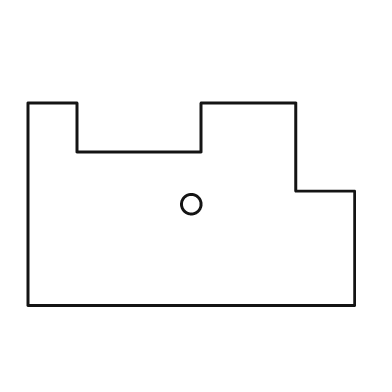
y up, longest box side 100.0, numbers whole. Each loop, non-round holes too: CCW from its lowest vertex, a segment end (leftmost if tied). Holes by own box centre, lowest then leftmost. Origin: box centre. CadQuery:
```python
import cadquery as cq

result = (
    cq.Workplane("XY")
    .moveTo(-50.0, -31.0)
    .lineTo(50.0, -31.0)
    .lineTo(50.0, 4.0)
    .lineTo(32.0, 4.0)
    .lineTo(32.0, 31.0)
    .lineTo(3.0, 31.0)
    .lineTo(3.0, 16.0)
    .lineTo(-35.0, 16.0)
    .lineTo(-35.0, 31.0)
    .lineTo(-50.0, 31.0)
    .close()
    .moveTo(0.0, 0.0)
    .circle(3.0)
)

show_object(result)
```